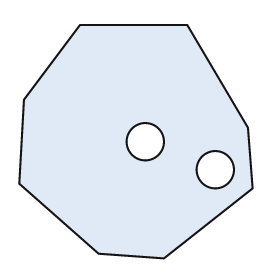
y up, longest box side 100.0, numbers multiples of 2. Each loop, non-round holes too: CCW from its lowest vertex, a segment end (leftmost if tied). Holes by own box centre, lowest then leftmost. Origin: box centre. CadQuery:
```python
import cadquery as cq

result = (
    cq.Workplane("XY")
    .moveTo(12.0, -50.0)
    .lineTo(50.0, -20.0)
    .lineTo(48.0, 6.0)
    .lineTo(22.0, 50.0)
    .lineTo(-24.0, 50.0)
    .lineTo(-48.0, 18.0)
    .lineTo(-50.0, -18.0)
    .lineTo(-16.0, -48.0)
    .close()
    .moveTo(34.0, -12.0)
    .circle(8.0)
    .moveTo(4.0, 0.0)
    .circle(8.0)
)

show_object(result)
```